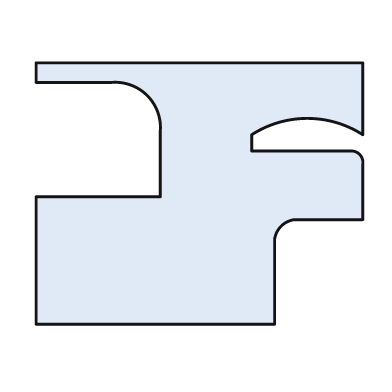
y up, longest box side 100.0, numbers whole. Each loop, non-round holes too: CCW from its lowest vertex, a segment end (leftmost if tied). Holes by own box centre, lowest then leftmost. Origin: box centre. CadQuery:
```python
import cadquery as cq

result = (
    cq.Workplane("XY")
    .moveTo(-50.0, -40.0)
    .lineTo(23.0, -40.0)
    .lineTo(23.0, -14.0)
    .threePointArc((25.0, -10.0), (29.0, -8.0))
    .lineTo(50.0, -8.0)
    .lineTo(50.0, 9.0)
    .threePointArc((49.0, 12.0), (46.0, 13.0))
    .lineTo(16.0, 13.0)
    .lineTo(16.0, 18.0)
    .threePointArc((33.0, 23.0), (50.0, 18.0))
    .lineTo(50.0, 40.0)
    .lineTo(-50.0, 40.0)
    .lineTo(-50.0, 34.0)
    .lineTo(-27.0, 34.0)
    .threePointArc((-16.0, 30.0), (-12.0, 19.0))
    .lineTo(-12.0, -1.0)
    .lineTo(-50.0, -1.0)
    .close()
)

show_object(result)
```